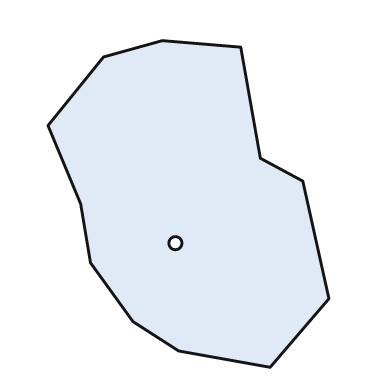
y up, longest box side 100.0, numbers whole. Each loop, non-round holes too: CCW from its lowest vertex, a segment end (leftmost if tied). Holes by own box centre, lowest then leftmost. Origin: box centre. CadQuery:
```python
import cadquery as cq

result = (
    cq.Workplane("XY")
    .moveTo(25.0, -50.0)
    .lineTo(43.0, -29.0)
    .lineTo(35.0, 7.0)
    .lineTo(22.0, 14.0)
    .lineTo(16.0, 48.0)
    .lineTo(-8.0, 50.0)
    .lineTo(-26.0, 45.0)
    .lineTo(-43.0, 24.0)
    .lineTo(-33.0, 0.0)
    .lineTo(-30.0, -18.0)
    .lineTo(-17.0, -36.0)
    .lineTo(-3.0, -45.0)
    .close()
    .moveTo(-4.0, -12.0)
    .circle(2.0)
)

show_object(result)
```